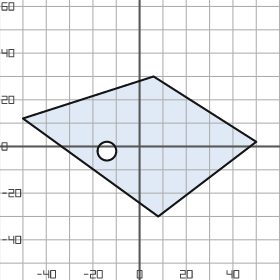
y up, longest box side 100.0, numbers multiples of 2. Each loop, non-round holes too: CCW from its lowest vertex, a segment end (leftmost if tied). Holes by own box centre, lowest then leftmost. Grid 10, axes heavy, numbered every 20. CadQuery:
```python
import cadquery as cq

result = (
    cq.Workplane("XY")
    .moveTo(8.0, -30.0)
    .lineTo(50.0, 2.0)
    .lineTo(6.0, 30.0)
    .lineTo(-50.0, 12.0)
    .close()
    .moveTo(-14.0, -2.0)
    .circle(4.0)
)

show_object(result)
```